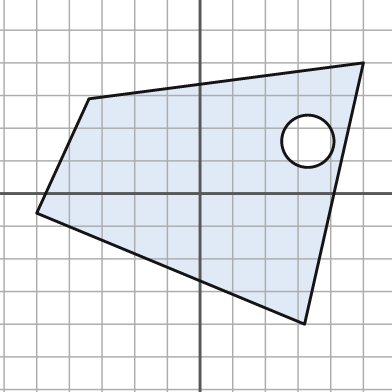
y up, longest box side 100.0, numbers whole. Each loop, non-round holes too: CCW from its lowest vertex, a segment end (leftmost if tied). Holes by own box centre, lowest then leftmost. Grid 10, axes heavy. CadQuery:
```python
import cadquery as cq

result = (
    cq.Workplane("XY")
    .moveTo(32.0, -40.0)
    .lineTo(50.0, 40.0)
    .lineTo(-34.0, 29.0)
    .lineTo(-50.0, -6.0)
    .close()
    .moveTo(33.0, 16.0)
    .circle(8.0)
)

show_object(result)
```